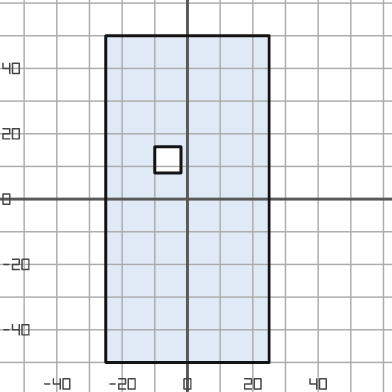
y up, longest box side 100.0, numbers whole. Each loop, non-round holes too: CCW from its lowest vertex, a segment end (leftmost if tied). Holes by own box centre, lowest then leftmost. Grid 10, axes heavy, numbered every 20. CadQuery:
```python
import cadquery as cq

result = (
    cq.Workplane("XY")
    .moveTo(-25.0, -50.0)
    .lineTo(25.0, -50.0)
    .lineTo(25.0, 50.0)
    .lineTo(-25.0, 50.0)
    .close()
    .moveTo(-10.0, 8.0)
    .lineTo(-2.0, 8.0)
    .lineTo(-2.0, 16.0)
    .lineTo(-10.0, 16.0)
    .close()
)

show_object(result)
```